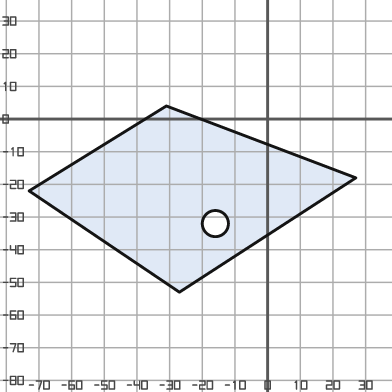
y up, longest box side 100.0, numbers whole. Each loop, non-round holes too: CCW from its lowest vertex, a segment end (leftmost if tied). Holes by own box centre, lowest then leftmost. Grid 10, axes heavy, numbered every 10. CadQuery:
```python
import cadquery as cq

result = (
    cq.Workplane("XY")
    .moveTo(-27.0, -53.0)
    .lineTo(27.0, -18.0)
    .lineTo(-31.0, 4.0)
    .lineTo(-73.0, -22.0)
    .close()
    .moveTo(-16.0, -32.0)
    .circle(4.0)
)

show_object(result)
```